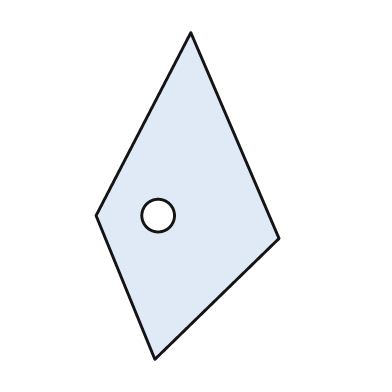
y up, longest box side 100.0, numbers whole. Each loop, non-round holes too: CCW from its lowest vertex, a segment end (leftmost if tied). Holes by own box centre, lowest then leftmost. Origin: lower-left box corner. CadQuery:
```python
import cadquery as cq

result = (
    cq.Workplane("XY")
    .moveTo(18.0, 0.0)
    .lineTo(56.0, 37.0)
    .lineTo(29.0, 100.0)
    .lineTo(0.0, 44.0)
    .close()
    .moveTo(19.0, 44.0)
    .circle(5.0)
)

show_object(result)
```